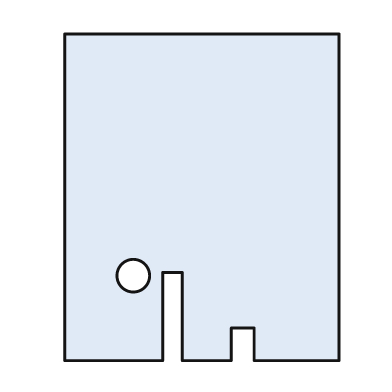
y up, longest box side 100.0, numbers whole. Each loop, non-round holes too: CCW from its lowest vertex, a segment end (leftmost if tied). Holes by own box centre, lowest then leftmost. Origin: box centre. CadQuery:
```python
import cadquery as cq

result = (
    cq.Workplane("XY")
    .moveTo(-42.0, -50.0)
    .lineTo(-12.0, -50.0)
    .lineTo(-12.0, -23.0)
    .lineTo(-6.0, -23.0)
    .lineTo(-6.0, -50.0)
    .lineTo(9.0, -50.0)
    .lineTo(9.0, -40.0)
    .lineTo(16.0, -40.0)
    .lineTo(16.0, -50.0)
    .lineTo(42.0, -50.0)
    .lineTo(42.0, 50.0)
    .lineTo(-42.0, 50.0)
    .close()
    .moveTo(-21.0, -24.0)
    .circle(5.0)
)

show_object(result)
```